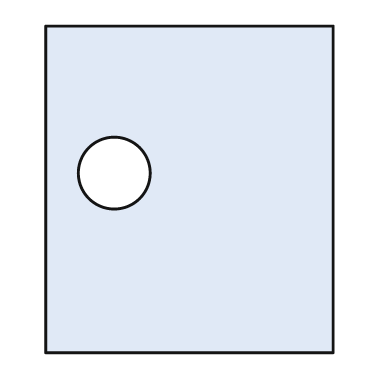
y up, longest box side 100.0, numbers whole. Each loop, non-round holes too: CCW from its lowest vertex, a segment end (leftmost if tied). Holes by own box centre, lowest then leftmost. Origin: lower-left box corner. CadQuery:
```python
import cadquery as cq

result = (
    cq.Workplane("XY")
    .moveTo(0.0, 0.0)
    .lineTo(88.0, 0.0)
    .lineTo(88.0, 100.0)
    .lineTo(0.0, 100.0)
    .close()
    .moveTo(21.0, 55.0)
    .circle(11.0)
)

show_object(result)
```